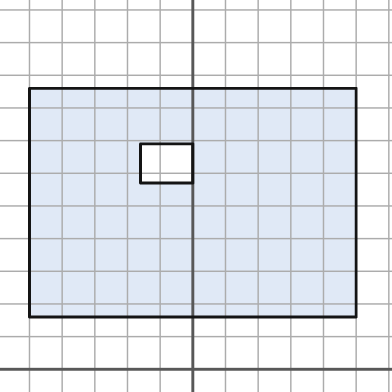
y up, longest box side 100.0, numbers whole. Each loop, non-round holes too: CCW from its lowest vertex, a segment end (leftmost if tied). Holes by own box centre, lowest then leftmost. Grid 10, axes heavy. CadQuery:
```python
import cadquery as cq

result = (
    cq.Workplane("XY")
    .moveTo(-50.0, 16.0)
    .lineTo(50.0, 16.0)
    .lineTo(50.0, 86.0)
    .lineTo(-50.0, 86.0)
    .close()
    .moveTo(-16.0, 57.0)
    .lineTo(0.0, 57.0)
    .lineTo(0.0, 69.0)
    .lineTo(-16.0, 69.0)
    .close()
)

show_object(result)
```